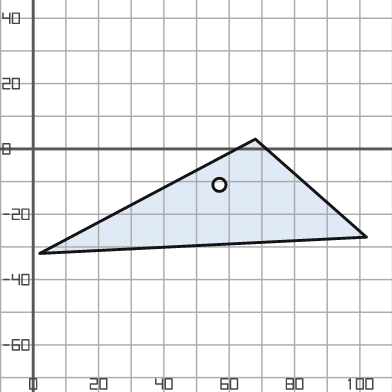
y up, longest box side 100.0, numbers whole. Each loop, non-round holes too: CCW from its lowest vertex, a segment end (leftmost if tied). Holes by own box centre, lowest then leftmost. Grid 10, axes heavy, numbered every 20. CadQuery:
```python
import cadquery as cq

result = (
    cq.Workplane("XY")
    .moveTo(2.0, -32.0)
    .lineTo(102.0, -27.0)
    .lineTo(68.0, 3.0)
    .close()
    .moveTo(57.0, -11.0)
    .circle(2.0)
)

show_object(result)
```